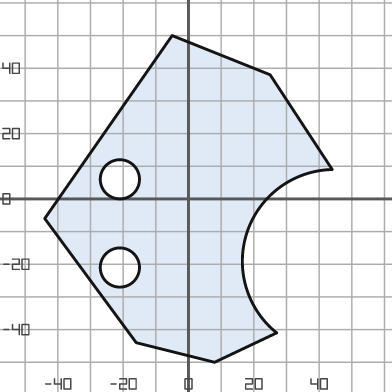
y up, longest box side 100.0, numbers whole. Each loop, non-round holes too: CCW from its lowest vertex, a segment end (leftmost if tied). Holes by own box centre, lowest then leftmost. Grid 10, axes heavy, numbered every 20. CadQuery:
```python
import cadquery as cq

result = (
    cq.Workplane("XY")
    .moveTo(8.0, -50.0)
    .lineTo(27.0, -41.0)
    .threePointArc((18.0, -10.0), (44.0, 9.0))
    .lineTo(25.0, 38.0)
    .lineTo(-5.0, 50.0)
    .lineTo(-44.0, -6.0)
    .lineTo(-16.0, -44.0)
    .close()
    .moveTo(-21.0, -21.0)
    .circle(6.0)
    .moveTo(-21.0, 6.0)
    .circle(6.0)
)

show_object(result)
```